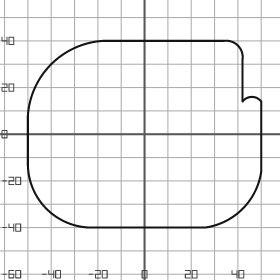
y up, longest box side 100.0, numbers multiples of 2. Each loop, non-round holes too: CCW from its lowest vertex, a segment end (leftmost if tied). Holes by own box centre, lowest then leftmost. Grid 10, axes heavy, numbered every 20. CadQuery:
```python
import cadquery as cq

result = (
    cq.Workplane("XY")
    .moveTo(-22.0, -40.0)
    .lineTo(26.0, -40.0)
    .threePointArc((42.0, -32.0), (50.0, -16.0))
    .lineTo(50.0, 14.0)
    .threePointArc((46.0, 16.0), (42.0, 14.0))
    .lineTo(42.0, 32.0)
    .threePointArc((40.0, 38.0), (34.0, 40.0))
    .lineTo(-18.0, 40.0)
    .threePointArc((-40.0, 30.0), (-50.0, 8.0))
    .lineTo(-50.0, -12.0)
    .threePointArc((-42.0, -32.0), (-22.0, -40.0))
    .close()
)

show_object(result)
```